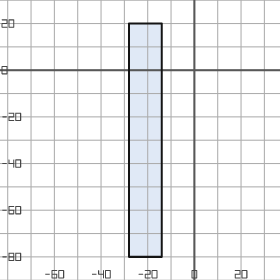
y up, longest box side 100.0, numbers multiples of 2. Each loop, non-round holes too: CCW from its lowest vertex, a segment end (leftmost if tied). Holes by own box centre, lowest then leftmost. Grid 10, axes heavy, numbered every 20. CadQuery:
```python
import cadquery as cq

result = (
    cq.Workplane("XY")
    .moveTo(-28.0, -80.0)
    .lineTo(-14.0, -80.0)
    .lineTo(-14.0, 20.0)
    .lineTo(-28.0, 20.0)
    .close()
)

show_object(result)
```